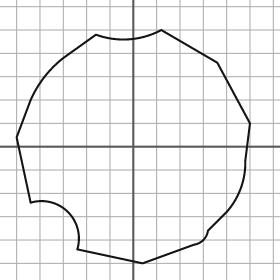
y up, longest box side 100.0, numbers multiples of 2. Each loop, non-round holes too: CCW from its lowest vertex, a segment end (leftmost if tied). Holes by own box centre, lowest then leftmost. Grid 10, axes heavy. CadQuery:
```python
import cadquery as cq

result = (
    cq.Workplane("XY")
    .moveTo(4.0, -50.0)
    .lineTo(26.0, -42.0)
    .threePointArc((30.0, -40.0), (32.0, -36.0))
    .lineTo(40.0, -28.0)
    .threePointArc((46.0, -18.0), (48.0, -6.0))
    .lineTo(50.0, 10.0)
    .lineTo(36.0, 36.0)
    .lineTo(12.0, 50.0)
    .threePointArc((-2.0, 46.0), (-16.0, 48.0))
    .lineTo(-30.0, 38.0)
    .threePointArc((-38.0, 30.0), (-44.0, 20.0))
    .lineTo(-50.0, 4.0)
    .lineTo(-44.0, -24.0)
    .threePointArc((-28.0, -28.0), (-24.0, -44.0))
    .close()
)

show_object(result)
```